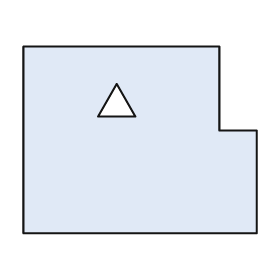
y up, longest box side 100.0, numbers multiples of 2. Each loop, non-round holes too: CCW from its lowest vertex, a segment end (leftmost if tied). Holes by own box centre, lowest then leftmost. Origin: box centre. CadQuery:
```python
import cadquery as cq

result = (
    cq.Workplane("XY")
    .moveTo(-50.0, -40.0)
    .lineTo(50.0, -40.0)
    .lineTo(50.0, 4.0)
    .lineTo(34.0, 4.0)
    .lineTo(34.0, 40.0)
    .lineTo(-50.0, 40.0)
    .close()
    .moveTo(-18.0, 10.0)
    .lineTo(-2.0, 10.0)
    .lineTo(-10.0, 24.0)
    .close()
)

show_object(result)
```